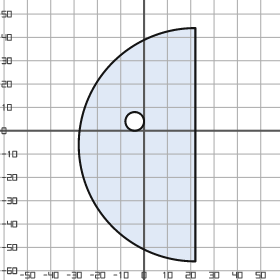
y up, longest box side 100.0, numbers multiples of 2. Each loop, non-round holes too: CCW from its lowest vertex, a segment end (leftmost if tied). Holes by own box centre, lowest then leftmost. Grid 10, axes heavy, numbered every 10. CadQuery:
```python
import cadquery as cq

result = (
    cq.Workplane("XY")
    .moveTo(22.0, -56.0)
    .lineTo(22.0, 44.0)
    .threePointArc((-28.0, -6.0), (22.0, -56.0))
    .close()
    .moveTo(-4.0, 4.0)
    .circle(4.0)
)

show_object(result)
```